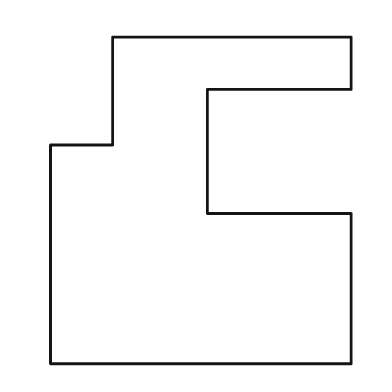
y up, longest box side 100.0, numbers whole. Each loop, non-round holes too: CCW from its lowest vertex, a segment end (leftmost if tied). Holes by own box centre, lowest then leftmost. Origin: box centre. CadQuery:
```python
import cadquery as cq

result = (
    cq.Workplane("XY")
    .moveTo(-46.0, -50.0)
    .lineTo(46.0, -50.0)
    .lineTo(46.0, -4.0)
    .lineTo(2.0, -4.0)
    .lineTo(2.0, 34.0)
    .lineTo(46.0, 34.0)
    .lineTo(46.0, 50.0)
    .lineTo(-27.0, 50.0)
    .lineTo(-27.0, 17.0)
    .lineTo(-46.0, 17.0)
    .close()
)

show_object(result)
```